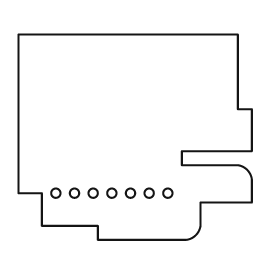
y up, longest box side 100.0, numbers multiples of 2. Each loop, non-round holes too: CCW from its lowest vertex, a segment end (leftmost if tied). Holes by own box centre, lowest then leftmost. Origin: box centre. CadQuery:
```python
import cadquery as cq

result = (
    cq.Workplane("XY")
    .moveTo(-16.0, -44.0)
    .lineTo(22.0, -44.0)
    .threePointArc((26.0, -42.0), (28.0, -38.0))
    .lineTo(28.0, -28.0)
    .lineTo(50.0, -28.0)
    .lineTo(50.0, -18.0)
    .threePointArc((48.0, -14.0), (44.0, -12.0))
    .lineTo(20.0, -12.0)
    .lineTo(20.0, -6.0)
    .lineTo(50.0, -6.0)
    .lineTo(50.0, 12.0)
    .lineTo(44.0, 12.0)
    .lineTo(44.0, 44.0)
    .lineTo(-50.0, 44.0)
    .lineTo(-50.0, -24.0)
    .lineTo(-40.0, -24.0)
    .lineTo(-40.0, -38.0)
    .lineTo(-16.0, -38.0)
    .close()
    .moveTo(-34.0, -24.0)
    .circle(2.0)
    .moveTo(-26.0, -24.0)
    .circle(2.0)
    .moveTo(-18.0, -24.0)
    .circle(2.0)
    .moveTo(-10.0, -24.0)
    .circle(2.0)
    .moveTo(-2.0, -24.0)
    .circle(2.0)
    .moveTo(6.0, -24.0)
    .circle(2.0)
    .moveTo(14.0, -24.0)
    .circle(2.0)
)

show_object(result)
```